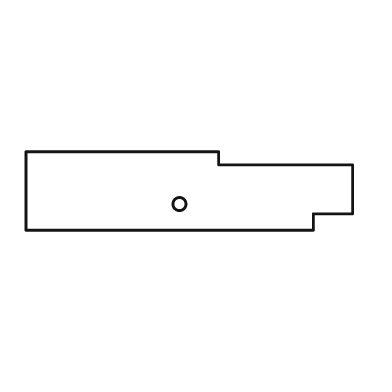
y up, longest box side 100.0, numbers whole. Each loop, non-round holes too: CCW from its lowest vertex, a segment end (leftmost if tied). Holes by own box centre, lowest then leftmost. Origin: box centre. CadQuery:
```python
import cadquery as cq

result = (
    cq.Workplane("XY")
    .moveTo(-50.0, -12.0)
    .lineTo(38.0, -12.0)
    .lineTo(38.0, -7.0)
    .lineTo(50.0, -7.0)
    .lineTo(50.0, 8.0)
    .lineTo(9.0, 8.0)
    .lineTo(9.0, 12.0)
    .lineTo(-50.0, 12.0)
    .close()
    .moveTo(-3.0, -4.0)
    .circle(2.0)
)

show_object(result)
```